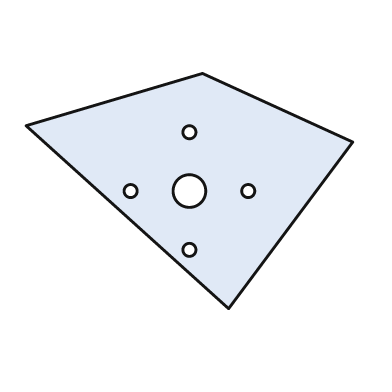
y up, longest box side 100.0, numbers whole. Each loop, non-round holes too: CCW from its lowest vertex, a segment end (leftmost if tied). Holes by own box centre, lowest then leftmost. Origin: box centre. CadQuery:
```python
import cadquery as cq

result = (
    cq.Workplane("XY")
    .moveTo(12.0, -36.0)
    .lineTo(50.0, 15.0)
    .lineTo(4.0, 36.0)
    .lineTo(-50.0, 20.0)
    .close()
    .moveTo(0.0, -18.0)
    .circle(2.0)
    .moveTo(-18.0, 0.0)
    .circle(2.0)
    .moveTo(0.0, 0.0)
    .circle(5.0)
    .moveTo(18.0, 0.0)
    .circle(2.0)
    .moveTo(0.0, 18.0)
    .circle(2.0)
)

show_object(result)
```